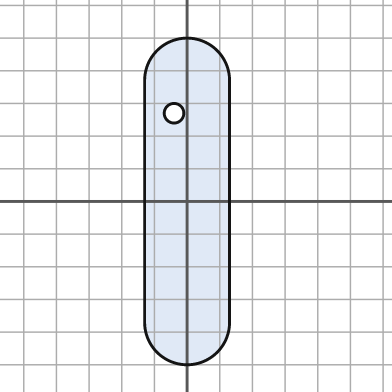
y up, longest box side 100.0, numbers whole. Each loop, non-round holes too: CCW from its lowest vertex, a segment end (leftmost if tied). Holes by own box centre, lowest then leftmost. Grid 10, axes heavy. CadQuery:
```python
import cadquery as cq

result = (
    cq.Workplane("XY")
    .moveTo(-13.0, -37.0)
    .threePointArc((0.0, -50.0), (13.0, -37.0))
    .lineTo(13.0, 37.0)
    .threePointArc((0.0, 50.0), (-13.0, 37.0))
    .close()
    .moveTo(-4.0, 27.0)
    .circle(3.0)
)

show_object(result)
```